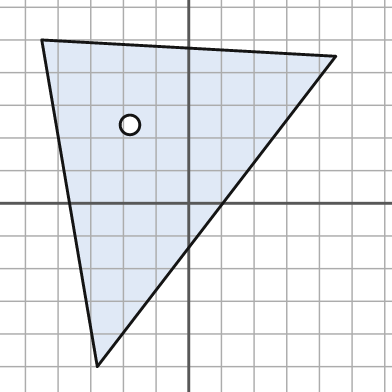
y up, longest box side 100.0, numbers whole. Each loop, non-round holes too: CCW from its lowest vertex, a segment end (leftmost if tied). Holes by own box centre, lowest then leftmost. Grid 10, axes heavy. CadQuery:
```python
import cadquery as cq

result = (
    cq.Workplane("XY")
    .moveTo(-28.0, -50.0)
    .lineTo(45.0, 45.0)
    .lineTo(-45.0, 50.0)
    .close()
    .moveTo(-18.0, 24.0)
    .circle(3.0)
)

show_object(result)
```